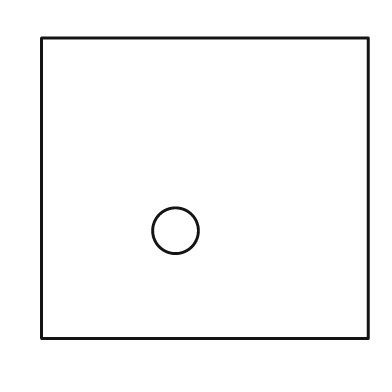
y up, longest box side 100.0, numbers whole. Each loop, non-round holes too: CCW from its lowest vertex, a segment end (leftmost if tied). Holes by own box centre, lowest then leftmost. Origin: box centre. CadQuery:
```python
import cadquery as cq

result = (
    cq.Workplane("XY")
    .moveTo(-50.0, -46.0)
    .lineTo(50.0, -46.0)
    .lineTo(50.0, 46.0)
    .lineTo(-50.0, 46.0)
    .close()
    .moveTo(-9.0, -13.0)
    .circle(7.0)
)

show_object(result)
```